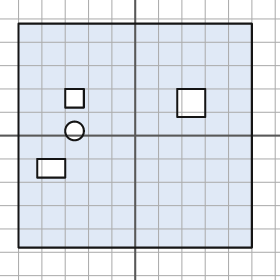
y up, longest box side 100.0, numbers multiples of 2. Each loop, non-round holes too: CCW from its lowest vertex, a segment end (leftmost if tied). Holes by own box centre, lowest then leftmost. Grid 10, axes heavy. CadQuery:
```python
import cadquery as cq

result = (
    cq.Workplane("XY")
    .moveTo(-50.0, -48.0)
    .lineTo(50.0, -48.0)
    .lineTo(50.0, 48.0)
    .lineTo(-50.0, 48.0)
    .close()
    .moveTo(-42.0, -18.0)
    .lineTo(-30.0, -18.0)
    .lineTo(-30.0, -10.0)
    .lineTo(-42.0, -10.0)
    .close()
    .moveTo(-26.0, 2.0)
    .circle(4.0)
    .moveTo(18.0, 8.0)
    .lineTo(30.0, 8.0)
    .lineTo(30.0, 20.0)
    .lineTo(18.0, 20.0)
    .close()
    .moveTo(-30.0, 12.0)
    .lineTo(-22.0, 12.0)
    .lineTo(-22.0, 20.0)
    .lineTo(-30.0, 20.0)
    .close()
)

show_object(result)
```